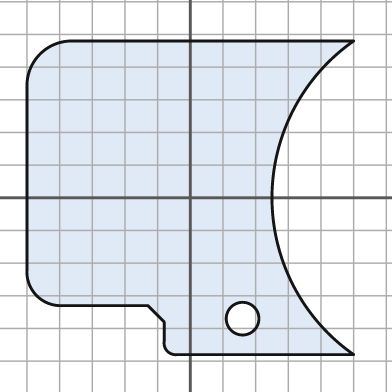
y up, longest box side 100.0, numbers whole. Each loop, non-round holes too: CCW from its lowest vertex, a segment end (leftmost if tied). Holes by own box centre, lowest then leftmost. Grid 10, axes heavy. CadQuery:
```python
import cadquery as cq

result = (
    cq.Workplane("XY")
    .moveTo(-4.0, -48.0)
    .lineTo(50.0, -48.0)
    .threePointArc((25.0, 0.0), (50.0, 48.0))
    .lineTo(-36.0, 48.0)
    .threePointArc((-46.0, 44.0), (-50.0, 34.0))
    .lineTo(-50.0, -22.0)
    .threePointArc((-47.0, -30.0), (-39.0, -33.0))
    .lineTo(-13.0, -33.0)
    .lineTo(-8.0, -38.0)
    .lineTo(-8.0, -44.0)
    .threePointArc((-7.0, -47.0), (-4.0, -48.0))
    .close()
    .moveTo(16.0, -37.0)
    .circle(5.0)
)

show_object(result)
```